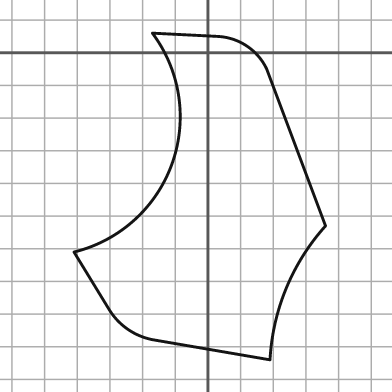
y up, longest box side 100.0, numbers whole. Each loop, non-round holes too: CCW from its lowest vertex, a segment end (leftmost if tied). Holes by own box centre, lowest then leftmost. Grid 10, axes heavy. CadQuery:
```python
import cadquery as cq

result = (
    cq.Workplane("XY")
    .moveTo(19.0, -94.0)
    .threePointArc((24.0, -72.0), (36.0, -53.0))
    .lineTo(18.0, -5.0)
    .threePointArc((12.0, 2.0), (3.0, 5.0))
    .lineTo(-17.0, 6.0)
    .threePointArc((-11.0, -34.0), (-41.0, -61.0))
    .lineTo(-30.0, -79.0)
    .threePointArc((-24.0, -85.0), (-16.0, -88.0))
    .close()
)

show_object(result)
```